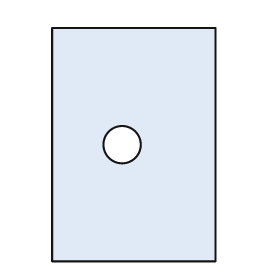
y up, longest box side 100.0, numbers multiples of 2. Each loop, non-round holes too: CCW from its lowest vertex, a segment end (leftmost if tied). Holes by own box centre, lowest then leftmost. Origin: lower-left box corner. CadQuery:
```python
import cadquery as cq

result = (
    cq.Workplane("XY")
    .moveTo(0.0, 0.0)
    .lineTo(70.0, 0.0)
    .lineTo(70.0, 100.0)
    .lineTo(0.0, 100.0)
    .close()
    .moveTo(30.0, 50.0)
    .circle(8.0)
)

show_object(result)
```